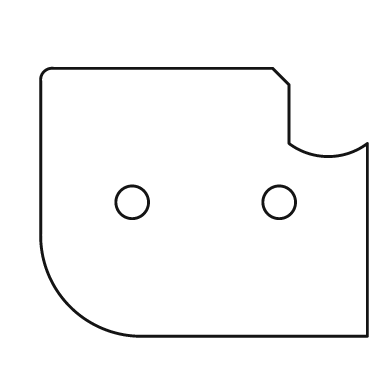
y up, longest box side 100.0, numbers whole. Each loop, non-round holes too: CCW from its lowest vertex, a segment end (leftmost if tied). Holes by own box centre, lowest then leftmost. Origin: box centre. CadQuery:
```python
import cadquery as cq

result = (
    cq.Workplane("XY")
    .moveTo(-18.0, -41.0)
    .lineTo(50.0, -41.0)
    .lineTo(50.0, 18.0)
    .threePointArc((38.0, 14.0), (26.0, 18.0))
    .lineTo(26.0, 36.0)
    .lineTo(21.0, 41.0)
    .lineTo(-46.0, 41.0)
    .threePointArc((-49.0, 40.0), (-50.0, 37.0))
    .lineTo(-50.0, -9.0)
    .threePointArc((-41.0, -32.0), (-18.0, -41.0))
    .close()
    .moveTo(-22.0, 0.0)
    .circle(5.0)
    .moveTo(23.0, 0.0)
    .circle(5.0)
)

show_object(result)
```